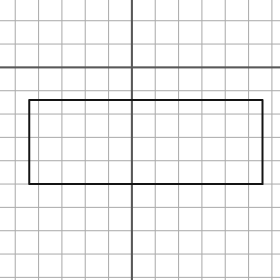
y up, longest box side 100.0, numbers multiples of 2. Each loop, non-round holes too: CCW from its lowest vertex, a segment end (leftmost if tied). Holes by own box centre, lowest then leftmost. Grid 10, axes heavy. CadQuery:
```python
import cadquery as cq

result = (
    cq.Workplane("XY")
    .moveTo(-44.0, -50.0)
    .lineTo(56.0, -50.0)
    .lineTo(56.0, -14.0)
    .lineTo(-44.0, -14.0)
    .close()
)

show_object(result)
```